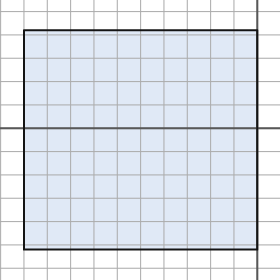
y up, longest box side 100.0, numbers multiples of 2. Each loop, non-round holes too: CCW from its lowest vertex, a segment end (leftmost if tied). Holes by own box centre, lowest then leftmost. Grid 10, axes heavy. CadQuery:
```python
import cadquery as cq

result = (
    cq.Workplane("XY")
    .moveTo(-100.0, -52.0)
    .lineTo(0.0, -52.0)
    .lineTo(0.0, 42.0)
    .lineTo(-100.0, 42.0)
    .close()
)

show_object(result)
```